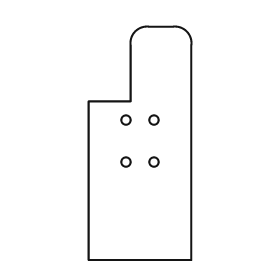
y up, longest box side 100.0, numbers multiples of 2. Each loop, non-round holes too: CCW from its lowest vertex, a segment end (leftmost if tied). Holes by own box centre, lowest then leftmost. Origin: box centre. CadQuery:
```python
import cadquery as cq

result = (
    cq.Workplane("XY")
    .moveTo(-22.0, -50.0)
    .lineTo(22.0, -50.0)
    .lineTo(22.0, 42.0)
    .threePointArc((20.0, 48.0), (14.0, 50.0))
    .lineTo(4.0, 50.0)
    .threePointArc((-2.0, 48.0), (-4.0, 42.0))
    .lineTo(-4.0, 18.0)
    .lineTo(-22.0, 18.0)
    .close()
    .moveTo(-6.0, -8.0)
    .circle(2.0)
    .moveTo(6.0, -8.0)
    .circle(2.0)
    .moveTo(-6.0, 10.0)
    .circle(2.0)
    .moveTo(6.0, 10.0)
    .circle(2.0)
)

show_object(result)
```